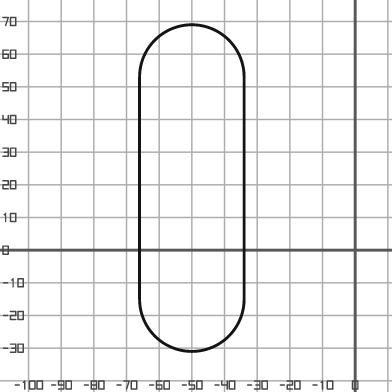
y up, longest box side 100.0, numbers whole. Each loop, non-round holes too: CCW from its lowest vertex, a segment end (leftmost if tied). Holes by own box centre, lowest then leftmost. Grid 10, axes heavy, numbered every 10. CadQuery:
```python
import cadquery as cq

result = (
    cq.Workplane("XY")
    .moveTo(-66.0, -15.0)
    .threePointArc((-50.0, -31.0), (-34.0, -15.0))
    .lineTo(-34.0, 53.0)
    .threePointArc((-50.0, 69.0), (-66.0, 53.0))
    .close()
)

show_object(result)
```